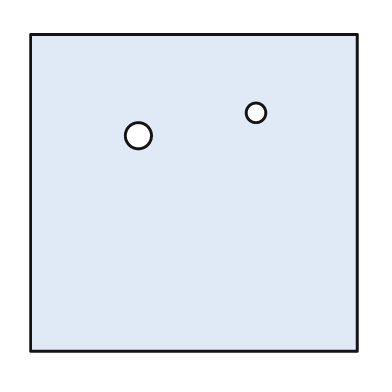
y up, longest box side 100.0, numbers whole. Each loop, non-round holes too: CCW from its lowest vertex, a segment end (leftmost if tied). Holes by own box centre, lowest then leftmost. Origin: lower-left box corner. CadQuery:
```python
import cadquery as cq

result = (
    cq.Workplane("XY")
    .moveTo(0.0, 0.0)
    .lineTo(100.0, 0.0)
    .lineTo(100.0, 97.0)
    .lineTo(0.0, 97.0)
    .close()
    .moveTo(33.0, 66.0)
    .circle(4.0)
    .moveTo(69.0, 73.0)
    .circle(3.0)
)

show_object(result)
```